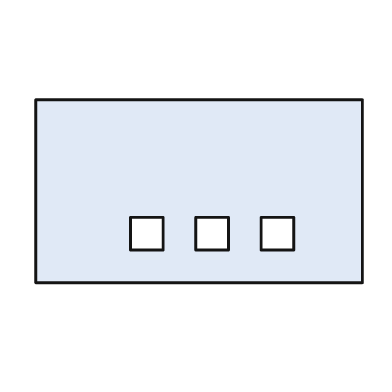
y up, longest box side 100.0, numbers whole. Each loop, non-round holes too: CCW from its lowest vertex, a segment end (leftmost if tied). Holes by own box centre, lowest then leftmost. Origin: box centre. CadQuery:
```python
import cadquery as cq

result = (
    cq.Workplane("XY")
    .moveTo(-50.0, -28.0)
    .lineTo(50.0, -28.0)
    .lineTo(50.0, 28.0)
    .lineTo(-50.0, 28.0)
    .close()
    .moveTo(-21.0, -18.0)
    .lineTo(-11.0, -18.0)
    .lineTo(-11.0, -8.0)
    .lineTo(-21.0, -8.0)
    .close()
    .moveTo(-1.0, -18.0)
    .lineTo(9.0, -18.0)
    .lineTo(9.0, -8.0)
    .lineTo(-1.0, -8.0)
    .close()
    .moveTo(19.0, -18.0)
    .lineTo(29.0, -18.0)
    .lineTo(29.0, -8.0)
    .lineTo(19.0, -8.0)
    .close()
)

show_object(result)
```